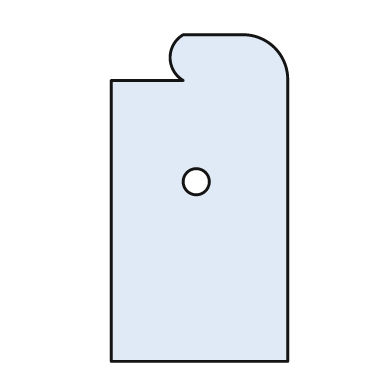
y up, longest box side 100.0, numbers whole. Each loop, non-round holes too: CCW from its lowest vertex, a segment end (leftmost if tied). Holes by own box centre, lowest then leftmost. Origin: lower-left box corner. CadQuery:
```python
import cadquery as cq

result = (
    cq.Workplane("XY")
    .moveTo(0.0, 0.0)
    .lineTo(54.0, 0.0)
    .lineTo(54.0, 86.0)
    .threePointArc((50.0, 96.0), (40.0, 100.0))
    .lineTo(22.0, 100.0)
    .threePointArc((18.0, 93.0), (22.0, 86.0))
    .lineTo(0.0, 86.0)
    .close()
    .moveTo(26.0, 55.0)
    .circle(4.0)
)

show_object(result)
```